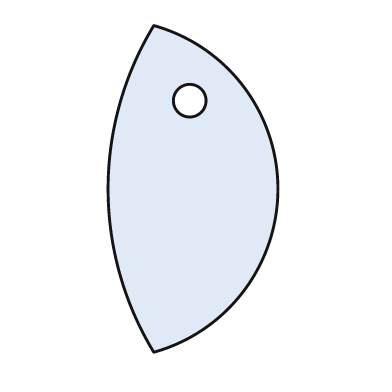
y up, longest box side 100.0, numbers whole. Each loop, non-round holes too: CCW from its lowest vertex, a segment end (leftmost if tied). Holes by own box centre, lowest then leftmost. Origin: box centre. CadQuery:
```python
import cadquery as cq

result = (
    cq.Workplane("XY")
    .moveTo(-12.0, -50.0)
    .threePointArc((26.0, 0.0), (-12.0, 50.0))
    .threePointArc((-26.0, 0.0), (-12.0, -50.0))
    .close()
    .moveTo(-1.0, 27.0)
    .circle(5.0)
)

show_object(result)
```